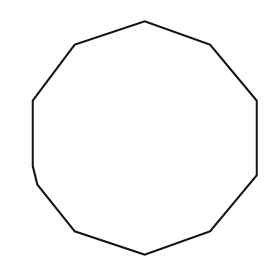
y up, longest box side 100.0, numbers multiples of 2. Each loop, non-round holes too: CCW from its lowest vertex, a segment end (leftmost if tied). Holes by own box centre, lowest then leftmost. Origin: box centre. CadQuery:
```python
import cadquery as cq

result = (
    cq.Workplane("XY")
    .moveTo(0.0, -50.0)
    .lineTo(28.0, -40.0)
    .lineTo(48.0, -16.0)
    .lineTo(48.0, 16.0)
    .lineTo(28.0, 40.0)
    .lineTo(0.0, 50.0)
    .lineTo(-30.0, 40.0)
    .lineTo(-48.0, 16.0)
    .lineTo(-48.0, -12.0)
    .lineTo(-46.0, -20.0)
    .lineTo(-30.0, -40.0)
    .close()
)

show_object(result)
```